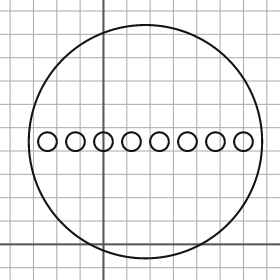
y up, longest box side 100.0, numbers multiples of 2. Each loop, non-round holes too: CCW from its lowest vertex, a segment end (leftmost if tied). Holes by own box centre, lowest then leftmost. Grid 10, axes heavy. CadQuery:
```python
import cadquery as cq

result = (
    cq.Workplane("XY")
    .moveTo(18.0, 44.0)
    .circle(50.0)
    .moveTo(-24.0, 44.0)
    .circle(4.0)
    .moveTo(-12.0, 44.0)
    .circle(4.0)
    .moveTo(0.0, 44.0)
    .circle(4.0)
    .moveTo(12.0, 44.0)
    .circle(4.0)
    .moveTo(24.0, 44.0)
    .circle(4.0)
    .moveTo(36.0, 44.0)
    .circle(4.0)
    .moveTo(48.0, 44.0)
    .circle(4.0)
    .moveTo(60.0, 44.0)
    .circle(4.0)
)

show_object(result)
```